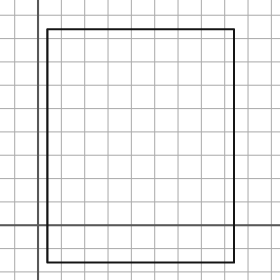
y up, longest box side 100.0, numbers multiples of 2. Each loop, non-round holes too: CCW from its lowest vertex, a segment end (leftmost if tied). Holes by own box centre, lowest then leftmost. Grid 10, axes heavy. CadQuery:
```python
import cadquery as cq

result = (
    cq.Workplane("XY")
    .moveTo(4.0, -16.0)
    .lineTo(84.0, -16.0)
    .lineTo(84.0, 84.0)
    .lineTo(4.0, 84.0)
    .close()
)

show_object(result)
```